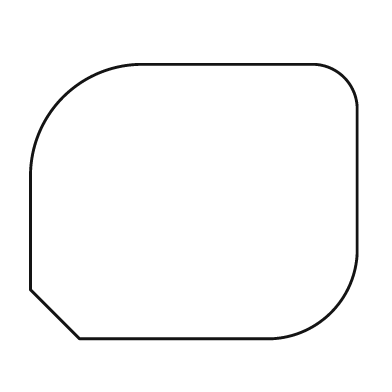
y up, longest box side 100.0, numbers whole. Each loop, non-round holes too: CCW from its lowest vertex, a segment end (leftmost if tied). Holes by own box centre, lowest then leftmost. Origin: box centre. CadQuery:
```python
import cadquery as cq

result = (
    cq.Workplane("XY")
    .moveTo(-35.0, -42.0)
    .lineTo(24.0, -42.0)
    .threePointArc((42.0, -34.0), (50.0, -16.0))
    .lineTo(50.0, 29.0)
    .threePointArc((46.0, 38.0), (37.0, 42.0))
    .lineTo(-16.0, 42.0)
    .threePointArc((-40.0, 32.0), (-50.0, 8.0))
    .lineTo(-50.0, -27.0)
    .close()
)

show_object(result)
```